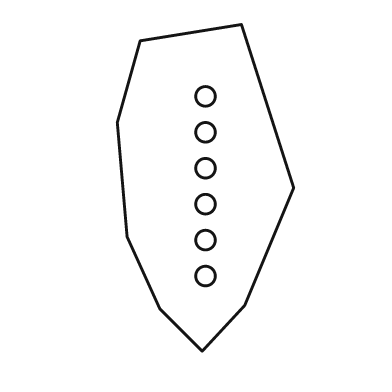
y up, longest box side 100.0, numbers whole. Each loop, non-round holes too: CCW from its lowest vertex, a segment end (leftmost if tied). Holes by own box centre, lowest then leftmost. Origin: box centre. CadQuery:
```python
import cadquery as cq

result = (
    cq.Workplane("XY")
    .moveTo(-1.0, -50.0)
    .lineTo(12.0, -36.0)
    .lineTo(27.0, 0.0)
    .lineTo(11.0, 50.0)
    .lineTo(-20.0, 45.0)
    .lineTo(-27.0, 20.0)
    .lineTo(-24.0, -15.0)
    .lineTo(-14.0, -37.0)
    .close()
    .moveTo(0.0, -27.0)
    .circle(3.0)
    .moveTo(0.0, -16.0)
    .circle(3.0)
    .moveTo(0.0, -5.0)
    .circle(3.0)
    .moveTo(0.0, 6.0)
    .circle(3.0)
    .moveTo(0.0, 17.0)
    .circle(3.0)
    .moveTo(0.0, 28.0)
    .circle(3.0)
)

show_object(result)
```